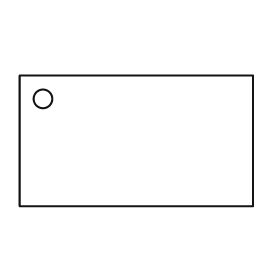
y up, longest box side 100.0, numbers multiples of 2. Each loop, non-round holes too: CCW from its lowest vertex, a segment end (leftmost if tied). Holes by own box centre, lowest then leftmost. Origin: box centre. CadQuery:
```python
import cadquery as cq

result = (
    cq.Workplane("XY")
    .moveTo(-50.0, -28.0)
    .lineTo(50.0, -28.0)
    .lineTo(50.0, 28.0)
    .lineTo(-50.0, 28.0)
    .close()
    .moveTo(-40.0, 18.0)
    .circle(4.0)
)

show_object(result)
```